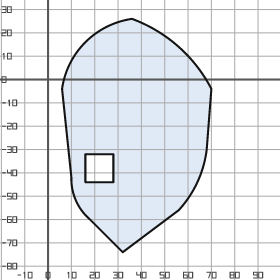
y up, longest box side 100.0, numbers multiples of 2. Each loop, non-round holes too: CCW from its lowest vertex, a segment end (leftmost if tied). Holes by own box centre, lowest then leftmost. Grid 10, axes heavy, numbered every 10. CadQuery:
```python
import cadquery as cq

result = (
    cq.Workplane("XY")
    .moveTo(32.0, -74.0)
    .lineTo(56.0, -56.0)
    .threePointArc((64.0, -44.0), (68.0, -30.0))
    .lineTo(70.0, -4.0)
    .threePointArc((56.0, 14.0), (36.0, 26.0))
    .threePointArc((16.0, 16.0), (6.0, -4.0))
    .lineTo(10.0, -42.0)
    .threePointArc((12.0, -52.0), (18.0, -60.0))
    .close()
    .moveTo(16.0, -44.0)
    .lineTo(28.0, -44.0)
    .lineTo(28.0, -32.0)
    .lineTo(16.0, -32.0)
    .close()
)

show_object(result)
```